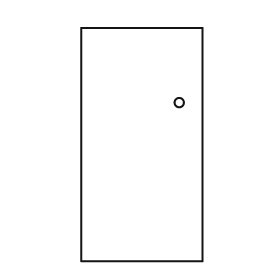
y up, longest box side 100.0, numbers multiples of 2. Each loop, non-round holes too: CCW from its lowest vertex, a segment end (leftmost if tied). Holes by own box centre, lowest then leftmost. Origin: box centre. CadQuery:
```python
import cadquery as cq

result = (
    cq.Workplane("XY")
    .moveTo(-26.0, -50.0)
    .lineTo(26.0, -50.0)
    .lineTo(26.0, 50.0)
    .lineTo(-26.0, 50.0)
    .close()
    .moveTo(16.0, 18.0)
    .circle(2.0)
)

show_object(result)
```